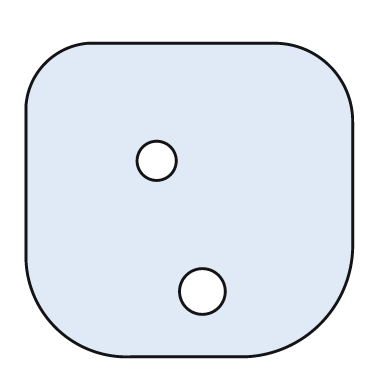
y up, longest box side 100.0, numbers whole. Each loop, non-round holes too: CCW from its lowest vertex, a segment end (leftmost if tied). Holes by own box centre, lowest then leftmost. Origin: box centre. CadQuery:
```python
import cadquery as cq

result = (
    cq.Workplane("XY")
    .moveTo(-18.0, -48.0)
    .lineTo(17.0, -48.0)
    .threePointArc((40.0, -38.0), (50.0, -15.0))
    .lineTo(50.0, 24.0)
    .threePointArc((43.0, 41.0), (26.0, 48.0))
    .lineTo(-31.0, 48.0)
    .threePointArc((-44.0, 42.0), (-50.0, 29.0))
    .lineTo(-50.0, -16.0)
    .threePointArc((-41.0, -39.0), (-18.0, -48.0))
    .close()
    .moveTo(4.0, -28.0)
    .circle(7.0)
    .moveTo(-10.0, 12.0)
    .circle(6.0)
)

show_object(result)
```